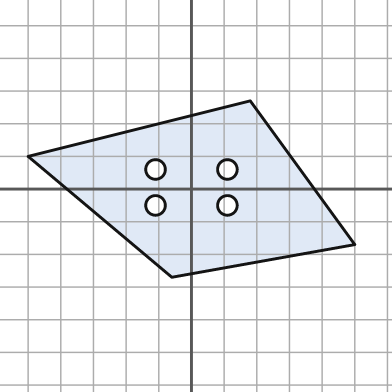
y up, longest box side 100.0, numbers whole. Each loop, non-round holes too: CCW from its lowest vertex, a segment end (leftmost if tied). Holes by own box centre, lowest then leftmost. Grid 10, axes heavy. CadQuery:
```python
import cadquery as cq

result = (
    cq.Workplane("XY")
    .moveTo(-6.0, -27.0)
    .lineTo(50.0, -17.0)
    .lineTo(18.0, 27.0)
    .lineTo(-50.0, 10.0)
    .close()
    .moveTo(-11.0, -5.0)
    .circle(3.0)
    .moveTo(11.0, -5.0)
    .circle(3.0)
    .moveTo(-11.0, 6.0)
    .circle(3.0)
    .moveTo(11.0, 6.0)
    .circle(3.0)
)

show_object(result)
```